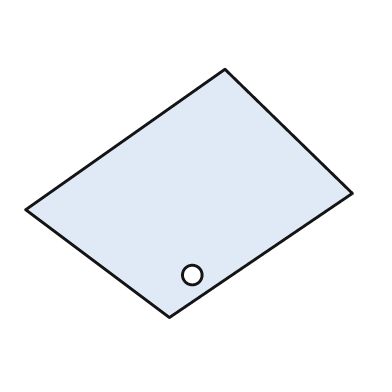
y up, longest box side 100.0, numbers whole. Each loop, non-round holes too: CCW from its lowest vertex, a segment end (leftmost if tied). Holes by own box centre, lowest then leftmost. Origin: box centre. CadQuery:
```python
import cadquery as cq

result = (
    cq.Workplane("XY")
    .moveTo(-6.0, -38.0)
    .lineTo(50.0, 0.0)
    .lineTo(11.0, 38.0)
    .lineTo(-50.0, -5.0)
    .close()
    .moveTo(1.0, -25.0)
    .circle(3.0)
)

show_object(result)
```